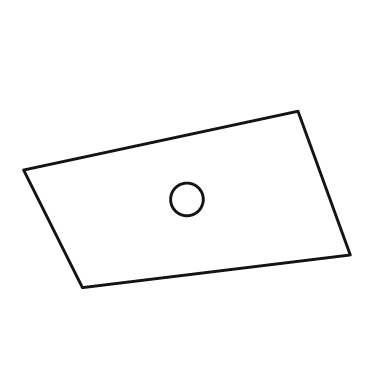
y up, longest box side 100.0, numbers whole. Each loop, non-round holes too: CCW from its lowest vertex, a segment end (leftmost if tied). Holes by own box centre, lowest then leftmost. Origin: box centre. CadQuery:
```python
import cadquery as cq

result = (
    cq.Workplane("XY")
    .moveTo(-32.0, -27.0)
    .lineTo(50.0, -17.0)
    .lineTo(34.0, 27.0)
    .lineTo(-50.0, 9.0)
    .close()
    .moveTo(0.0, 0.0)
    .circle(5.0)
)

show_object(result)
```